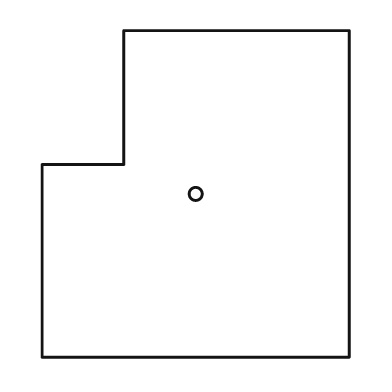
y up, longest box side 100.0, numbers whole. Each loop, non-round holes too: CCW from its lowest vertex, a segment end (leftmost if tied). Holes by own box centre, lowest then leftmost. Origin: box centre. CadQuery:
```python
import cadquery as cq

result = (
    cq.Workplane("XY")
    .moveTo(-47.0, -50.0)
    .lineTo(47.0, -50.0)
    .lineTo(47.0, 50.0)
    .lineTo(-22.0, 50.0)
    .lineTo(-22.0, 9.0)
    .lineTo(-47.0, 9.0)
    .close()
    .moveTo(0.0, 0.0)
    .circle(2.0)
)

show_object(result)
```